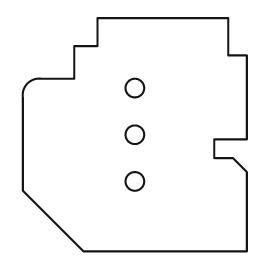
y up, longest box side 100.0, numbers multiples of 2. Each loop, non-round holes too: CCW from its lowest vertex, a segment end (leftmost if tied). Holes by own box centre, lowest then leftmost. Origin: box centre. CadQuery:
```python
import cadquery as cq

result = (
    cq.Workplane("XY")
    .moveTo(-22.0, -50.0)
    .lineTo(48.0, -50.0)
    .lineTo(48.0, -16.0)
    .lineTo(42.0, -10.0)
    .lineTo(34.0, -10.0)
    .lineTo(34.0, -2.0)
    .lineTo(48.0, -2.0)
    .lineTo(48.0, 34.0)
    .lineTo(40.0, 34.0)
    .lineTo(40.0, 50.0)
    .lineTo(-16.0, 50.0)
    .lineTo(-16.0, 38.0)
    .lineTo(-26.0, 38.0)
    .lineTo(-26.0, 24.0)
    .lineTo(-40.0, 24.0)
    .threePointArc((-46.0, 22.0), (-48.0, 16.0))
    .lineTo(-48.0, -24.0)
    .close()
    .moveTo(0.0, -20.0)
    .circle(4.0)
    .moveTo(0.0, 0.0)
    .circle(4.0)
    .moveTo(0.0, 20.0)
    .circle(4.0)
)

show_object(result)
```